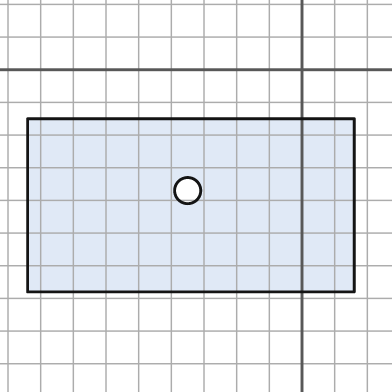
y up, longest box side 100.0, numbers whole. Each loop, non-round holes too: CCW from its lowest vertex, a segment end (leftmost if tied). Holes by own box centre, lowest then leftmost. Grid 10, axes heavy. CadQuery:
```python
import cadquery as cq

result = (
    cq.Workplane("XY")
    .moveTo(-84.0, -68.0)
    .lineTo(16.0, -68.0)
    .lineTo(16.0, -15.0)
    .lineTo(-84.0, -15.0)
    .close()
    .moveTo(-35.0, -37.0)
    .circle(4.0)
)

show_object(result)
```